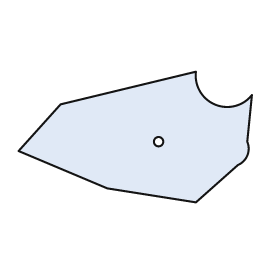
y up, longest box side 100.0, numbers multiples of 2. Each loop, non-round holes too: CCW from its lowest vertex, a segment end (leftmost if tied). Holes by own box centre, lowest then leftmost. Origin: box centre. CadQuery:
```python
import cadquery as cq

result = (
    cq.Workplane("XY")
    .moveTo(26.0, -28.0)
    .lineTo(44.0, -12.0)
    .threePointArc((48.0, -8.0), (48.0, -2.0))
    .lineTo(50.0, 18.0)
    .threePointArc((34.0, 14.0), (26.0, 28.0))
    .lineTo(-32.0, 14.0)
    .lineTo(-50.0, -6.0)
    .lineTo(-12.0, -22.0)
    .close()
    .moveTo(10.0, -2.0)
    .circle(2.0)
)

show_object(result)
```